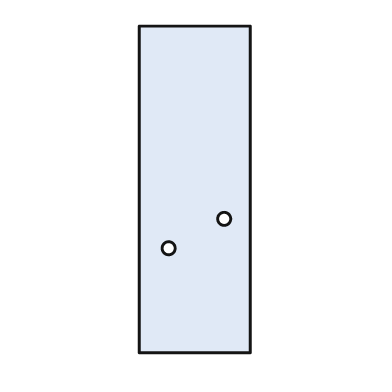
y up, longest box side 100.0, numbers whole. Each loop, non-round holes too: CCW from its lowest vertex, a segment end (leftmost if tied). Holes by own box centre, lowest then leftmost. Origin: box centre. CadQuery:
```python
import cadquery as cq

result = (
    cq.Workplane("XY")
    .moveTo(-17.0, -50.0)
    .lineTo(17.0, -50.0)
    .lineTo(17.0, 50.0)
    .lineTo(-17.0, 50.0)
    .close()
    .moveTo(-8.0, -18.0)
    .circle(2.0)
    .moveTo(9.0, -9.0)
    .circle(2.0)
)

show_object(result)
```